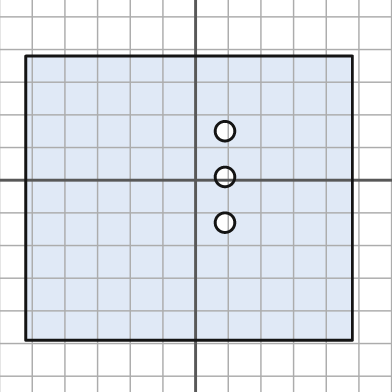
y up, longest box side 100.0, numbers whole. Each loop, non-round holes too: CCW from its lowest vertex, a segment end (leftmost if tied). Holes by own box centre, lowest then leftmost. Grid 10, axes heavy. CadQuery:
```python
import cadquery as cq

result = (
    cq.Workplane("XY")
    .moveTo(-52.0, -49.0)
    .lineTo(48.0, -49.0)
    .lineTo(48.0, 38.0)
    .lineTo(-52.0, 38.0)
    .close()
    .moveTo(9.0, -13.0)
    .circle(3.0)
    .moveTo(9.0, 1.0)
    .circle(3.0)
    .moveTo(9.0, 15.0)
    .circle(3.0)
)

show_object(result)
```